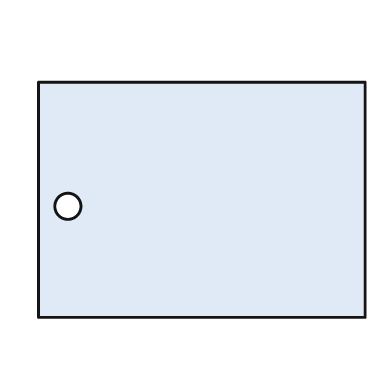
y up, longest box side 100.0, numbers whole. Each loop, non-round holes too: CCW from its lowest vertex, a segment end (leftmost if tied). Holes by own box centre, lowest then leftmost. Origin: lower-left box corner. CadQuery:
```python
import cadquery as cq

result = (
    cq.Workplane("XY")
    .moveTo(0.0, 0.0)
    .lineTo(100.0, 0.0)
    .lineTo(100.0, 72.0)
    .lineTo(0.0, 72.0)
    .close()
    .moveTo(9.0, 34.0)
    .circle(4.0)
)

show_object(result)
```